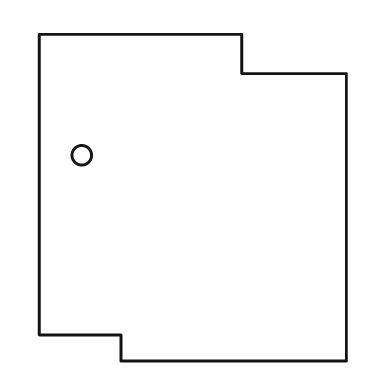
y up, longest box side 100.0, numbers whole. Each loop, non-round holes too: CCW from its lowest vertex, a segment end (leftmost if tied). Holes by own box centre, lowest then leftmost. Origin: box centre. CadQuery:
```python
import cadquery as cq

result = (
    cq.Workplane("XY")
    .moveTo(-22.0, -50.0)
    .lineTo(47.0, -50.0)
    .lineTo(47.0, 38.0)
    .lineTo(15.0, 38.0)
    .lineTo(15.0, 50.0)
    .lineTo(-47.0, 50.0)
    .lineTo(-47.0, -42.0)
    .lineTo(-22.0, -42.0)
    .close()
    .moveTo(-34.0, 13.0)
    .circle(3.0)
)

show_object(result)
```